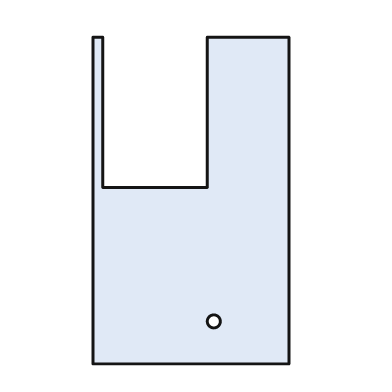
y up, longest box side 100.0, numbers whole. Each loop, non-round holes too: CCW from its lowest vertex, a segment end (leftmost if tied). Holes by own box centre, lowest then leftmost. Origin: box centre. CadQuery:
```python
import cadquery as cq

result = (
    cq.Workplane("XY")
    .moveTo(-30.0, -50.0)
    .lineTo(30.0, -50.0)
    .lineTo(30.0, 50.0)
    .lineTo(5.0, 50.0)
    .lineTo(5.0, 4.0)
    .lineTo(-27.0, 4.0)
    .lineTo(-27.0, 50.0)
    .lineTo(-30.0, 50.0)
    .close()
    .moveTo(7.0, -37.0)
    .circle(2.0)
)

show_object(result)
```